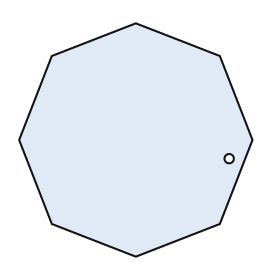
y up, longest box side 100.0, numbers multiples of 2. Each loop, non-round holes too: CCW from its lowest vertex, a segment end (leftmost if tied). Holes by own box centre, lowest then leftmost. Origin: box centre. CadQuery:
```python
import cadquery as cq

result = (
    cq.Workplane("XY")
    .moveTo(0.0, -50.0)
    .lineTo(36.0, -36.0)
    .lineTo(50.0, 0.0)
    .lineTo(36.0, 36.0)
    .lineTo(0.0, 50.0)
    .lineTo(-36.0, 36.0)
    .lineTo(-50.0, 0.0)
    .lineTo(-36.0, -36.0)
    .close()
    .moveTo(40.0, -8.0)
    .circle(2.0)
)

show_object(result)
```